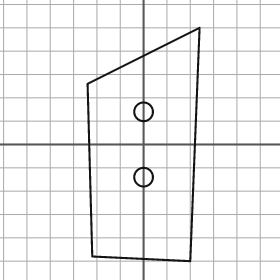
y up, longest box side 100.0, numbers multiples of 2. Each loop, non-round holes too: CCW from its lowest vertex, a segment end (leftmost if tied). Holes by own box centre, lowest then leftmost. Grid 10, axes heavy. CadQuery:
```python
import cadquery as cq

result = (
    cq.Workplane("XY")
    .moveTo(20.0, -50.0)
    .lineTo(24.0, 50.0)
    .lineTo(-24.0, 26.0)
    .lineTo(-22.0, -48.0)
    .close()
    .moveTo(0.0, -14.0)
    .circle(4.0)
    .moveTo(0.0, 14.0)
    .circle(4.0)
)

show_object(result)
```